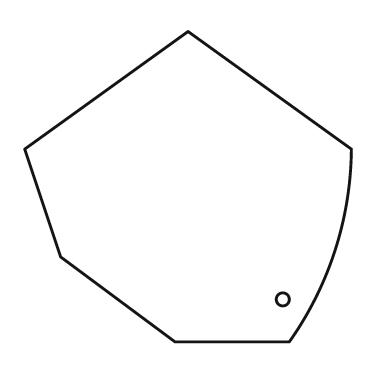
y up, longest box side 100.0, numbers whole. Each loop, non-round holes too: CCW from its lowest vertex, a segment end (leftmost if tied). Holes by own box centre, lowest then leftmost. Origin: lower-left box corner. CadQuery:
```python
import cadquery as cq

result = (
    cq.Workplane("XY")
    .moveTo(46.0, 0.0)
    .lineTo(81.0, 0.0)
    .threePointArc((95.0, 28.0), (100.0, 59.0))
    .lineTo(50.0, 95.0)
    .lineTo(0.0, 59.0)
    .lineTo(11.0, 26.0)
    .close()
    .moveTo(79.0, 13.0)
    .circle(2.0)
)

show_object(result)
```